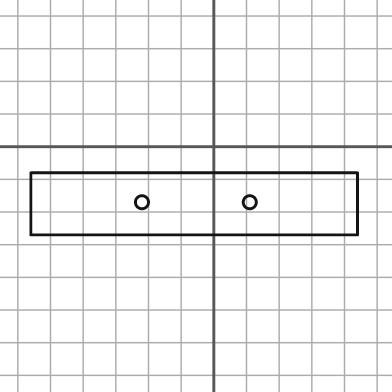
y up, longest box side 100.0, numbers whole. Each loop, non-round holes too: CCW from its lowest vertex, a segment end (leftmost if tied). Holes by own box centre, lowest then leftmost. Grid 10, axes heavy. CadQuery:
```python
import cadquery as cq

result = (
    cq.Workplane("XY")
    .moveTo(-56.0, -27.0)
    .lineTo(44.0, -27.0)
    .lineTo(44.0, -8.0)
    .lineTo(-56.0, -8.0)
    .close()
    .moveTo(-22.0, -17.0)
    .circle(2.0)
    .moveTo(11.0, -17.0)
    .circle(2.0)
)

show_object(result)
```